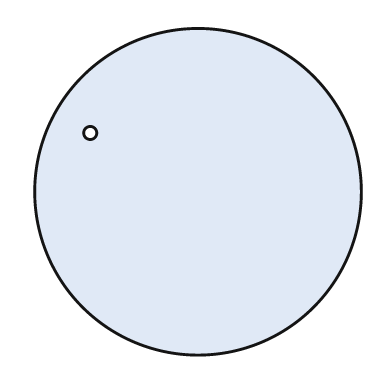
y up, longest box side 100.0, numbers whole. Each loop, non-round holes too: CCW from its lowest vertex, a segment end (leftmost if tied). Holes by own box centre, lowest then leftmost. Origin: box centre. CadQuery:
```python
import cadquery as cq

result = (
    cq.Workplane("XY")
    .moveTo(0.0, 0.0)
    .circle(50.0)
    .moveTo(-33.0, 18.0)
    .circle(2.0)
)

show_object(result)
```